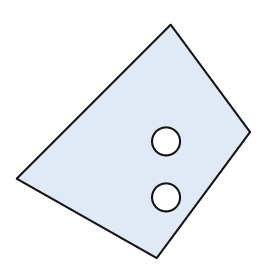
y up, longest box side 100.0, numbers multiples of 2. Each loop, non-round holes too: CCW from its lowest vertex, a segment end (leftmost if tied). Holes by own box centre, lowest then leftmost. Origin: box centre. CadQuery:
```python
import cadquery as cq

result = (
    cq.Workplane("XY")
    .moveTo(10.0, -50.0)
    .lineTo(50.0, 4.0)
    .lineTo(16.0, 50.0)
    .lineTo(-50.0, -16.0)
    .close()
    .moveTo(14.0, -24.0)
    .circle(6.0)
    .moveTo(14.0, 0.0)
    .circle(6.0)
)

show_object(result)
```